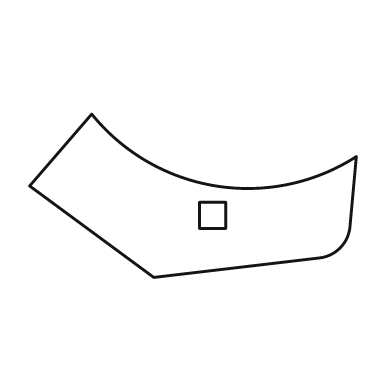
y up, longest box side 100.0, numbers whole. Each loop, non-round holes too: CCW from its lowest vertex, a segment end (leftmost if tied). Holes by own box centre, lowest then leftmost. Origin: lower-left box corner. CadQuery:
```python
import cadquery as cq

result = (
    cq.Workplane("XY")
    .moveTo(38.0, 0.0)
    .lineTo(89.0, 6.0)
    .threePointArc((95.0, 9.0), (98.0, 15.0))
    .lineTo(100.0, 37.0)
    .threePointArc((57.0, 28.0), (19.0, 50.0))
    .lineTo(0.0, 28.0)
    .close()
    .moveTo(52.0, 15.0)
    .lineTo(60.0, 15.0)
    .lineTo(60.0, 23.0)
    .lineTo(52.0, 23.0)
    .close()
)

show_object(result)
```